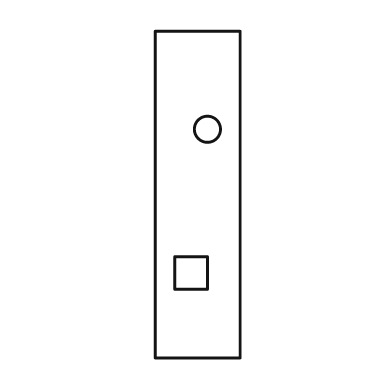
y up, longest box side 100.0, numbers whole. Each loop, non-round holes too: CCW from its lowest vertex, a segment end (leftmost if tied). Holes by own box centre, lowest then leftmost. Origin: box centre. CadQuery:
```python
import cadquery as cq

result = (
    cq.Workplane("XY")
    .moveTo(-13.0, -50.0)
    .lineTo(13.0, -50.0)
    .lineTo(13.0, 50.0)
    .lineTo(-13.0, 50.0)
    .close()
    .moveTo(-7.0, -29.0)
    .lineTo(3.0, -29.0)
    .lineTo(3.0, -19.0)
    .lineTo(-7.0, -19.0)
    .close()
    .moveTo(3.0, 20.0)
    .circle(4.0)
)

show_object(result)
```